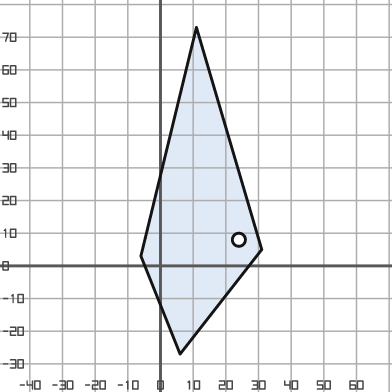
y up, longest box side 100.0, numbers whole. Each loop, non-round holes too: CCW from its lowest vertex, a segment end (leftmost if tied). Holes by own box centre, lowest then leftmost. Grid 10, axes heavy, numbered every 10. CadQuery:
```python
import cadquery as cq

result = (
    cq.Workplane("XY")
    .moveTo(6.0, -27.0)
    .lineTo(31.0, 5.0)
    .lineTo(11.0, 73.0)
    .lineTo(-6.0, 3.0)
    .close()
    .moveTo(24.0, 8.0)
    .circle(2.0)
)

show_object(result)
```